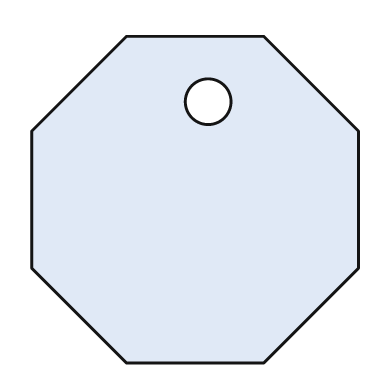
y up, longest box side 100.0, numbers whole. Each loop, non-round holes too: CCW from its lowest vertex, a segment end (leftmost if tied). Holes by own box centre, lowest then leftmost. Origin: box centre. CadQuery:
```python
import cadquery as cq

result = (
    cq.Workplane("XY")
    .moveTo(-21.0, -50.0)
    .lineTo(21.0, -50.0)
    .lineTo(50.0, -21.0)
    .lineTo(50.0, 21.0)
    .lineTo(21.0, 50.0)
    .lineTo(-21.0, 50.0)
    .lineTo(-50.0, 21.0)
    .lineTo(-50.0, -21.0)
    .close()
    .moveTo(4.0, 30.0)
    .circle(7.0)
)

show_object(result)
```